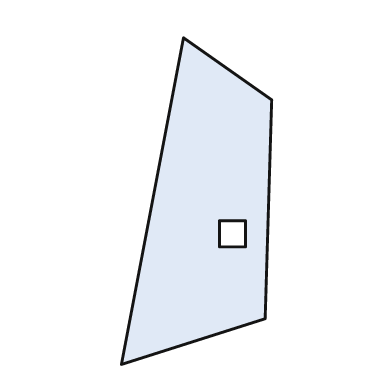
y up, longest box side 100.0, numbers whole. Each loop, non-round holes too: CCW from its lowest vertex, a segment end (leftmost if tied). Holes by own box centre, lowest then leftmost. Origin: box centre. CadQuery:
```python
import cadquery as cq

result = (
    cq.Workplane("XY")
    .moveTo(-23.0, -50.0)
    .lineTo(21.0, -36.0)
    .lineTo(23.0, 31.0)
    .lineTo(-4.0, 50.0)
    .close()
    .moveTo(7.0, -14.0)
    .lineTo(15.0, -14.0)
    .lineTo(15.0, -6.0)
    .lineTo(7.0, -6.0)
    .close()
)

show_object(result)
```